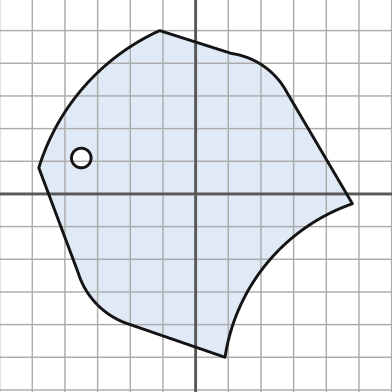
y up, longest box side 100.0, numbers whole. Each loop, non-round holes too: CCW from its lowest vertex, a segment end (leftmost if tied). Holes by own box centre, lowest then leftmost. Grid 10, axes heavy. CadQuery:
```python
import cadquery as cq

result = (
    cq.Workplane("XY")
    .moveTo(9.0, -50.0)
    .threePointArc((22.0, -21.0), (48.0, -3.0))
    .lineTo(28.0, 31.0)
    .threePointArc((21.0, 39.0), (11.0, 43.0))
    .lineTo(-11.0, 50.0)
    .threePointArc((-34.0, 33.0), (-48.0, 8.0))
    .lineTo(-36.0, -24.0)
    .threePointArc((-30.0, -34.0), (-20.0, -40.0))
    .close()
    .moveTo(-35.0, 11.0)
    .circle(3.0)
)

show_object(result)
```